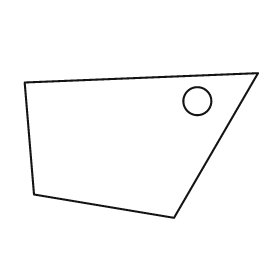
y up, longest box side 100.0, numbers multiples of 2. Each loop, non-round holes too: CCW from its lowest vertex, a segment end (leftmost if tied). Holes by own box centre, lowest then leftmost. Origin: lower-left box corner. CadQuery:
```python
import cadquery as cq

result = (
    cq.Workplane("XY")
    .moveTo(64.0, 0.0)
    .lineTo(100.0, 62.0)
    .lineTo(0.0, 58.0)
    .lineTo(4.0, 10.0)
    .close()
    .moveTo(74.0, 50.0)
    .circle(6.0)
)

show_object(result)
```